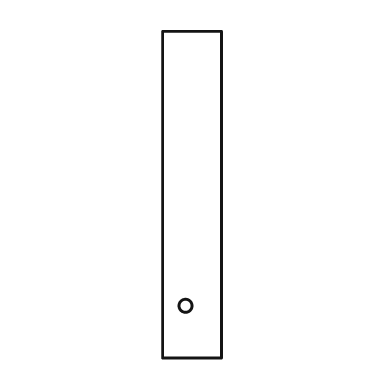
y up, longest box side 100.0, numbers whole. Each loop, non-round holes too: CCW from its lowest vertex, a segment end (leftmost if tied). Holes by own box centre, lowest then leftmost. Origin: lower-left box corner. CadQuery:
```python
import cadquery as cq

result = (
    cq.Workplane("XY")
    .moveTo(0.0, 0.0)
    .lineTo(18.0, 0.0)
    .lineTo(18.0, 100.0)
    .lineTo(0.0, 100.0)
    .close()
    .moveTo(7.0, 16.0)
    .circle(2.0)
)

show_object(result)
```